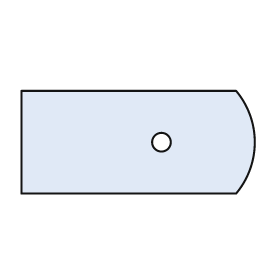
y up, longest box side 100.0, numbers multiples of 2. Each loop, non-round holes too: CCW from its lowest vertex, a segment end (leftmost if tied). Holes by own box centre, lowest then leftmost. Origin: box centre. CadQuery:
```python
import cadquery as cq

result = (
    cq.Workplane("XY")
    .moveTo(-50.0, -22.0)
    .lineTo(42.0, -22.0)
    .threePointArc((50.0, 0.0), (42.0, 22.0))
    .lineTo(-50.0, 22.0)
    .close()
    .moveTo(10.0, 0.0)
    .circle(4.0)
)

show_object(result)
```